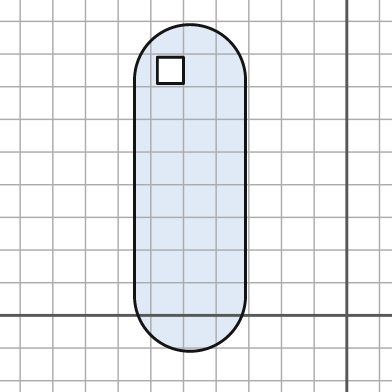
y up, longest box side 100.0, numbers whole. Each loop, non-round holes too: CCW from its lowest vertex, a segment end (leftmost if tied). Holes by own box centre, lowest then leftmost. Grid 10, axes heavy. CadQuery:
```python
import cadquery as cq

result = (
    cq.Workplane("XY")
    .moveTo(-65.0, 6.0)
    .threePointArc((-48.0, -11.0), (-31.0, 6.0))
    .lineTo(-31.0, 72.0)
    .threePointArc((-48.0, 89.0), (-65.0, 72.0))
    .close()
    .moveTo(-58.0, 71.0)
    .lineTo(-50.0, 71.0)
    .lineTo(-50.0, 79.0)
    .lineTo(-58.0, 79.0)
    .close()
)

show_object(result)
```